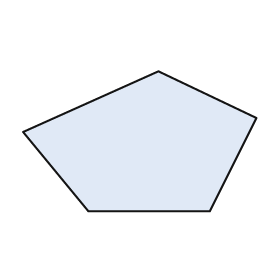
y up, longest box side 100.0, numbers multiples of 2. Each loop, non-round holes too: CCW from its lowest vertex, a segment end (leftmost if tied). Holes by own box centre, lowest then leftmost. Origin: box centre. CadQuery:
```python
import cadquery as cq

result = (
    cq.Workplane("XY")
    .moveTo(-22.0, -30.0)
    .lineTo(30.0, -30.0)
    .lineTo(50.0, 10.0)
    .lineTo(8.0, 30.0)
    .lineTo(-50.0, 4.0)
    .close()
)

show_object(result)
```